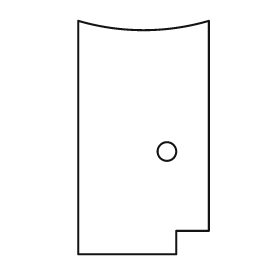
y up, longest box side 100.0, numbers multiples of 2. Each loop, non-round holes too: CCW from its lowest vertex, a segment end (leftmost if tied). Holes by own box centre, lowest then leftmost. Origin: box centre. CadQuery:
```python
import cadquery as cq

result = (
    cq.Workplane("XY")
    .moveTo(-28.0, -50.0)
    .lineTo(14.0, -50.0)
    .lineTo(14.0, -40.0)
    .lineTo(28.0, -40.0)
    .lineTo(28.0, 50.0)
    .threePointArc((0.0, 46.0), (-28.0, 50.0))
    .close()
    .moveTo(10.0, -6.0)
    .circle(4.0)
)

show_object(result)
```